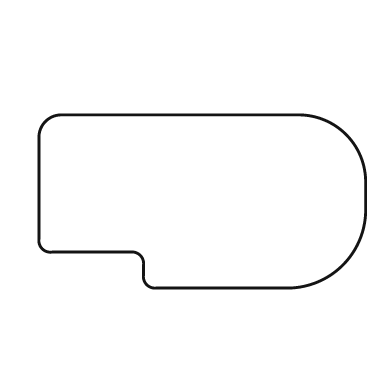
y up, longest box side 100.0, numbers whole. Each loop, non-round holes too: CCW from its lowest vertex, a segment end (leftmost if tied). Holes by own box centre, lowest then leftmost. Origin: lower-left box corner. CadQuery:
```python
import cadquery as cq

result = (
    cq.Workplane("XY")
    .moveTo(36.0, 0.0)
    .lineTo(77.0, 0.0)
    .threePointArc((93.0, 7.0), (100.0, 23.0))
    .lineTo(100.0, 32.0)
    .threePointArc((94.0, 47.0), (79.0, 53.0))
    .lineTo(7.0, 53.0)
    .threePointArc((2.0, 51.0), (0.0, 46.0))
    .lineTo(0.0, 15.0)
    .threePointArc((1.0, 12.0), (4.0, 11.0))
    .lineTo(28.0, 11.0)
    .threePointArc((31.0, 10.0), (32.0, 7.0))
    .lineTo(32.0, 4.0)
    .threePointArc((33.0, 1.0), (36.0, 0.0))
    .close()
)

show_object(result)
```